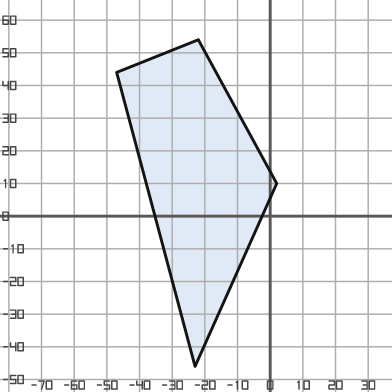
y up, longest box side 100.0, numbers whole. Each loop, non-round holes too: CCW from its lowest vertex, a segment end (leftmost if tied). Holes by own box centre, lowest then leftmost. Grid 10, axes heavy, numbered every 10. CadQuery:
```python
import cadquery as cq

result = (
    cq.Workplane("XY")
    .moveTo(-23.0, -46.0)
    .lineTo(2.0, 10.0)
    .lineTo(-22.0, 54.0)
    .lineTo(-47.0, 44.0)
    .close()
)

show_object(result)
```